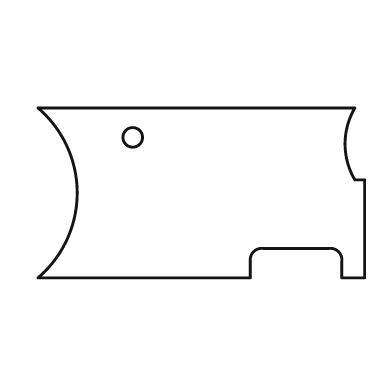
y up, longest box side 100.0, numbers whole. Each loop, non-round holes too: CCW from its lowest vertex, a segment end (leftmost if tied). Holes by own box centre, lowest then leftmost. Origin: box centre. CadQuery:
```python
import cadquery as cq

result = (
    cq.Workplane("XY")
    .moveTo(-50.0, -26.0)
    .lineTo(15.0, -26.0)
    .lineTo(15.0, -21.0)
    .threePointArc((16.0, -18.0), (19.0, -17.0))
    .lineTo(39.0, -17.0)
    .threePointArc((42.0, -18.0), (43.0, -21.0))
    .lineTo(43.0, -26.0)
    .lineTo(50.0, -26.0)
    .lineTo(50.0, 4.0)
    .lineTo(47.0, 4.0)
    .threePointArc((44.0, 15.0), (47.0, 26.0))
    .lineTo(-50.0, 26.0)
    .threePointArc((-38.0, 0.0), (-50.0, -26.0))
    .close()
    .moveTo(-21.0, 17.0)
    .circle(3.0)
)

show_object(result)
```